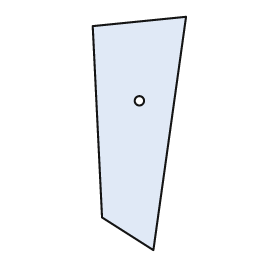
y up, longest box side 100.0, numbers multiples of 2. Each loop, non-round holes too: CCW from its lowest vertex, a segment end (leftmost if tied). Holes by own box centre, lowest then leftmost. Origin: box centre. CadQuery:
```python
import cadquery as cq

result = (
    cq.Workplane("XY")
    .moveTo(6.0, -50.0)
    .lineTo(20.0, 50.0)
    .lineTo(-20.0, 46.0)
    .lineTo(-16.0, -36.0)
    .close()
    .moveTo(0.0, 14.0)
    .circle(2.0)
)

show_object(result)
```